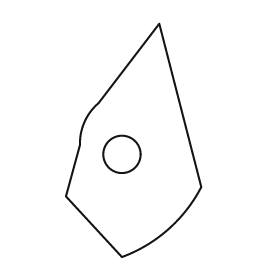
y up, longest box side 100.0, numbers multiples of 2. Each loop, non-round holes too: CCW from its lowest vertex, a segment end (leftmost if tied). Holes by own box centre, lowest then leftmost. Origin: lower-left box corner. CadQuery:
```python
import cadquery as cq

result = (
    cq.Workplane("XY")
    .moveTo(24.0, 0.0)
    .threePointArc((44.0, 12.0), (58.0, 30.0))
    .lineTo(40.0, 100.0)
    .lineTo(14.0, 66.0)
    .threePointArc((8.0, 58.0), (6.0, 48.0))
    .lineTo(0.0, 26.0)
    .close()
    .moveTo(24.0, 44.0)
    .circle(8.0)
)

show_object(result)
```